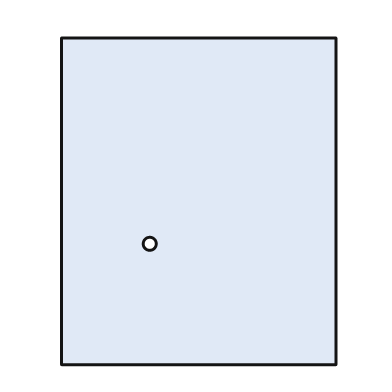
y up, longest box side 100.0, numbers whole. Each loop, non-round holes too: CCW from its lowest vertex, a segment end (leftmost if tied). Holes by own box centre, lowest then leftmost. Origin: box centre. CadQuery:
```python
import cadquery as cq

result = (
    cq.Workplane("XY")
    .moveTo(-42.0, -50.0)
    .lineTo(42.0, -50.0)
    .lineTo(42.0, 50.0)
    .lineTo(-42.0, 50.0)
    .close()
    .moveTo(-15.0, -13.0)
    .circle(2.0)
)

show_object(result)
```